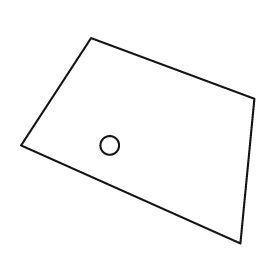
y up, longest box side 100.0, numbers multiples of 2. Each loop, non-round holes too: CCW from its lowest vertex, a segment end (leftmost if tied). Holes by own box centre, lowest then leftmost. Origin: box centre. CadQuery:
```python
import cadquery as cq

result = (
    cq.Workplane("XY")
    .moveTo(44.0, -44.0)
    .lineTo(50.0, 18.0)
    .lineTo(-20.0, 44.0)
    .lineTo(-50.0, -2.0)
    .close()
    .moveTo(-12.0, -2.0)
    .circle(4.0)
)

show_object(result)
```